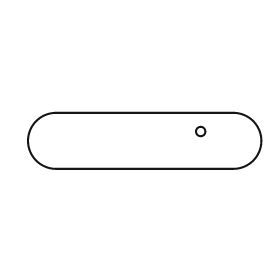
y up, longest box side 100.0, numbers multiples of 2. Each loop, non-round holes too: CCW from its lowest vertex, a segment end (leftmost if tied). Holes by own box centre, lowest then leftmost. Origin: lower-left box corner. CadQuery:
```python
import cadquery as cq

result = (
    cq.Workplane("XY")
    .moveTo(12.0, 0.0)
    .lineTo(88.0, 0.0)
    .threePointArc((100.0, 12.0), (88.0, 24.0))
    .lineTo(12.0, 24.0)
    .threePointArc((0.0, 12.0), (12.0, 0.0))
    .close()
    .moveTo(74.0, 16.0)
    .circle(2.0)
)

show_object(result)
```